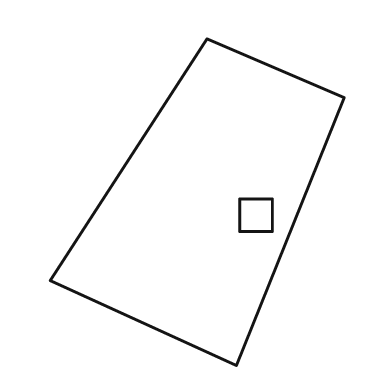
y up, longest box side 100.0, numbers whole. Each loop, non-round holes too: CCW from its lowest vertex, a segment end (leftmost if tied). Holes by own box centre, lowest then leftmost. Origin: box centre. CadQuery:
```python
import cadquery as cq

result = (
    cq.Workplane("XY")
    .moveTo(12.0, -50.0)
    .lineTo(45.0, 32.0)
    .lineTo(3.0, 50.0)
    .lineTo(-45.0, -24.0)
    .close()
    .moveTo(13.0, -9.0)
    .lineTo(23.0, -9.0)
    .lineTo(23.0, 1.0)
    .lineTo(13.0, 1.0)
    .close()
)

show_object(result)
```